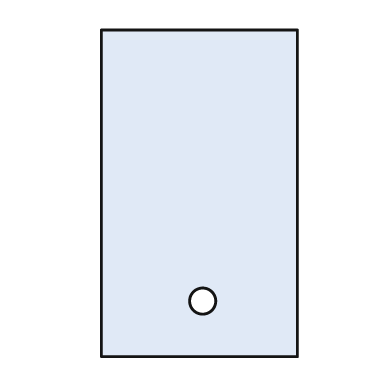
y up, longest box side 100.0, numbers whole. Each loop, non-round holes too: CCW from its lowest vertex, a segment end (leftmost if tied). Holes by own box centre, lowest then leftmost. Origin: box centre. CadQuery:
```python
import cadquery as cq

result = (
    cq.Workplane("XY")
    .moveTo(-30.0, -50.0)
    .lineTo(30.0, -50.0)
    .lineTo(30.0, 50.0)
    .lineTo(-30.0, 50.0)
    .close()
    .moveTo(1.0, -33.0)
    .circle(4.0)
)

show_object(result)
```